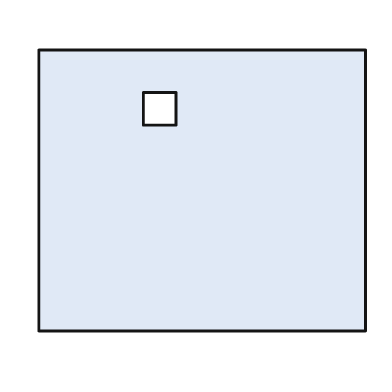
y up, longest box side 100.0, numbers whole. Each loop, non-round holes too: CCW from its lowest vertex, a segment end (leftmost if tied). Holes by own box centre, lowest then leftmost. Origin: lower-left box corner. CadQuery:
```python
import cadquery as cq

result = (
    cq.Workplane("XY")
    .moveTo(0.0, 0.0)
    .lineTo(100.0, 0.0)
    .lineTo(100.0, 86.0)
    .lineTo(0.0, 86.0)
    .close()
    .moveTo(32.0, 63.0)
    .lineTo(42.0, 63.0)
    .lineTo(42.0, 73.0)
    .lineTo(32.0, 73.0)
    .close()
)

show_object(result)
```